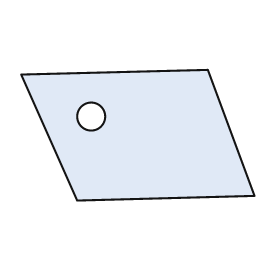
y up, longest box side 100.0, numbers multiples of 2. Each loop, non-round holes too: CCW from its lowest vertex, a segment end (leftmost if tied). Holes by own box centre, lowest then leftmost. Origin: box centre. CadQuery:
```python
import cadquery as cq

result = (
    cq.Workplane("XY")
    .moveTo(-26.0, -28.0)
    .lineTo(50.0, -26.0)
    .lineTo(30.0, 28.0)
    .lineTo(-50.0, 26.0)
    .close()
    .moveTo(-20.0, 8.0)
    .circle(6.0)
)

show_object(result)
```